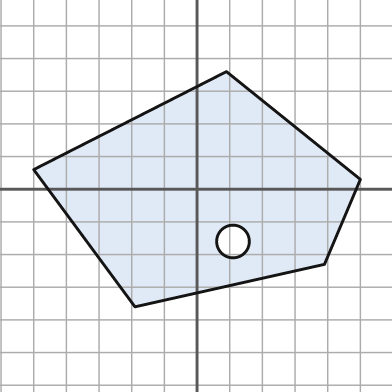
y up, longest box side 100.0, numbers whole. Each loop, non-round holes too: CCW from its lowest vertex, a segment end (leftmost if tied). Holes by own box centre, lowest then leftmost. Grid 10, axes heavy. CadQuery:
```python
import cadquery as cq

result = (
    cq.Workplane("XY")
    .moveTo(-19.0, -36.0)
    .lineTo(39.0, -23.0)
    .lineTo(50.0, 3.0)
    .lineTo(9.0, 36.0)
    .lineTo(-50.0, 6.0)
    .close()
    .moveTo(11.0, -16.0)
    .circle(5.0)
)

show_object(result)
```